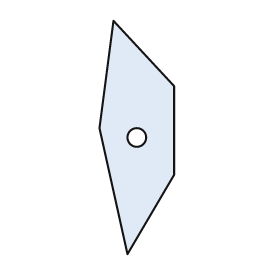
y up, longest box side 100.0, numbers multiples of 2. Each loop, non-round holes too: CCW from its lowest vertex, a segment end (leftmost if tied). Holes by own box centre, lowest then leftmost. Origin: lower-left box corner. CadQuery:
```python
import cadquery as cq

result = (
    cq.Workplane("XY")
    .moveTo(12.0, 0.0)
    .lineTo(32.0, 34.0)
    .lineTo(32.0, 72.0)
    .lineTo(6.0, 100.0)
    .lineTo(0.0, 54.0)
    .close()
    .moveTo(16.0, 50.0)
    .circle(4.0)
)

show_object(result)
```